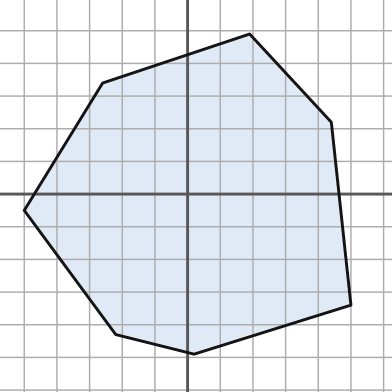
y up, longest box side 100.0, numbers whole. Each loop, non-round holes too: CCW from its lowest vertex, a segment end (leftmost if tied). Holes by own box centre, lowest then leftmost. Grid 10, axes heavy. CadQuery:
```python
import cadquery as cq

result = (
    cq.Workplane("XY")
    .moveTo(2.0, -49.0)
    .lineTo(50.0, -34.0)
    .lineTo(44.0, 22.0)
    .lineTo(19.0, 49.0)
    .lineTo(-26.0, 34.0)
    .lineTo(-50.0, -5.0)
    .lineTo(-22.0, -43.0)
    .close()
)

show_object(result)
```